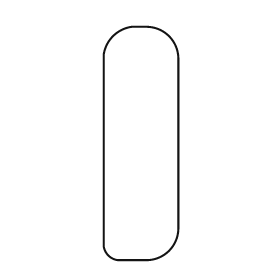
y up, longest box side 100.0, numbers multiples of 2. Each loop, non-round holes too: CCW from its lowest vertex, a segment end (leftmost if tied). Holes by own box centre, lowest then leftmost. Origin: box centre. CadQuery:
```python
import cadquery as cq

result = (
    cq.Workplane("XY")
    .moveTo(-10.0, -50.0)
    .lineTo(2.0, -50.0)
    .threePointArc((12.0, -46.0), (16.0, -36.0))
    .lineTo(16.0, 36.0)
    .threePointArc((12.0, 46.0), (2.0, 50.0))
    .lineTo(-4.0, 50.0)
    .threePointArc((-12.0, 46.0), (-16.0, 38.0))
    .lineTo(-16.0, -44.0)
    .threePointArc((-14.0, -48.0), (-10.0, -50.0))
    .close()
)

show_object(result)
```